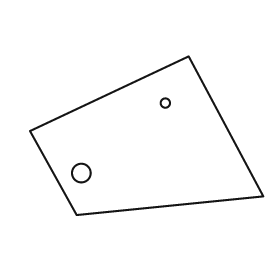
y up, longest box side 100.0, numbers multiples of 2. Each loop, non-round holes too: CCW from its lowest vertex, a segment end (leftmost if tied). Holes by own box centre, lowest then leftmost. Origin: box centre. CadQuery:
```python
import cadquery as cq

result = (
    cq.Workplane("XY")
    .moveTo(-30.0, -34.0)
    .lineTo(50.0, -26.0)
    .lineTo(18.0, 34.0)
    .lineTo(-50.0, 2.0)
    .close()
    .moveTo(-28.0, -16.0)
    .circle(4.0)
    .moveTo(8.0, 14.0)
    .circle(2.0)
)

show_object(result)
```